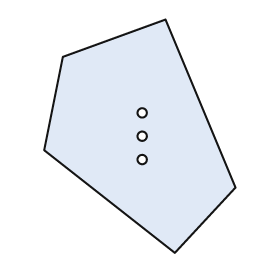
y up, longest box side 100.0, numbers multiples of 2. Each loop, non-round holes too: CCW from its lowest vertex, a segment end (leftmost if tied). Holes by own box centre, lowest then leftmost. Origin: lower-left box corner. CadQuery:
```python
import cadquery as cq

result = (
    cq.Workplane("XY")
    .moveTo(56.0, 0.0)
    .lineTo(82.0, 28.0)
    .lineTo(52.0, 100.0)
    .lineTo(8.0, 84.0)
    .lineTo(0.0, 44.0)
    .close()
    .moveTo(42.0, 40.0)
    .circle(2.0)
    .moveTo(42.0, 50.0)
    .circle(2.0)
    .moveTo(42.0, 60.0)
    .circle(2.0)
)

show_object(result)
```